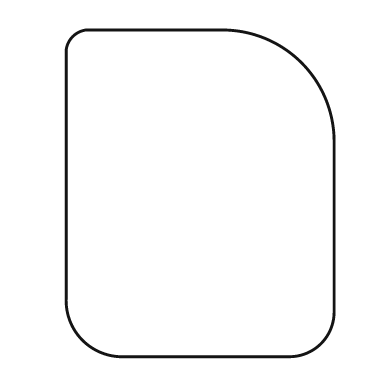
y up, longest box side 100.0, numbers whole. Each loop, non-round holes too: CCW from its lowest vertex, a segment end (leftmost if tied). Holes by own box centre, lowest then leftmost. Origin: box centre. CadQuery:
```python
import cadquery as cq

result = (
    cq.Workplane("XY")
    .moveTo(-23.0, -50.0)
    .lineTo(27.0, -50.0)
    .threePointArc((37.0, -46.0), (41.0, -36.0))
    .lineTo(41.0, 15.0)
    .threePointArc((31.0, 40.0), (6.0, 50.0))
    .lineTo(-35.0, 50.0)
    .threePointArc((-39.0, 48.0), (-41.0, 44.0))
    .lineTo(-41.0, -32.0)
    .threePointArc((-36.0, -45.0), (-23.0, -50.0))
    .close()
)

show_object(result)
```